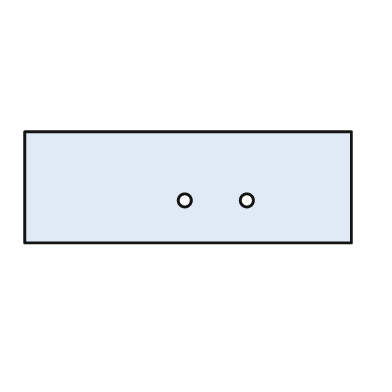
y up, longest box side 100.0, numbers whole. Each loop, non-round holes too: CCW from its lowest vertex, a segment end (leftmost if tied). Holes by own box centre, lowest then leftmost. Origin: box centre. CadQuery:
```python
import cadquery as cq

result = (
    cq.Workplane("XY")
    .moveTo(-50.0, -17.0)
    .lineTo(50.0, -17.0)
    .lineTo(50.0, 17.0)
    .lineTo(-50.0, 17.0)
    .close()
    .moveTo(-1.0, -4.0)
    .circle(2.0)
    .moveTo(18.0, -4.0)
    .circle(2.0)
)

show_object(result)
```